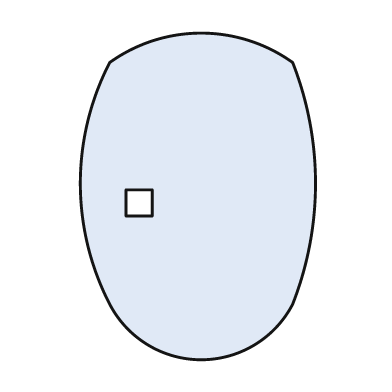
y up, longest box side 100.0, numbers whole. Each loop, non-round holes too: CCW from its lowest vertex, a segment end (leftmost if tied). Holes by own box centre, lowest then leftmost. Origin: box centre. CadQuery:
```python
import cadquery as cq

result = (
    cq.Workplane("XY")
    .moveTo(-27.0, -33.0)
    .threePointArc((1.0, -50.0), (29.0, -33.0))
    .threePointArc((36.0, 4.0), (29.0, 41.0))
    .threePointArc((1.0, 50.0), (-27.0, 41.0))
    .threePointArc((-36.0, 4.0), (-27.0, -33.0))
    .close()
    .moveTo(-22.0, -6.0)
    .lineTo(-14.0, -6.0)
    .lineTo(-14.0, 2.0)
    .lineTo(-22.0, 2.0)
    .close()
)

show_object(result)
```